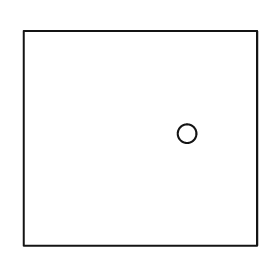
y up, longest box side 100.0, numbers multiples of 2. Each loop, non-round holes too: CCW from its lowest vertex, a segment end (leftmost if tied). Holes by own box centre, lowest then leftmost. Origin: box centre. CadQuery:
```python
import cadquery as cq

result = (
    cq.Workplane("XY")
    .moveTo(-50.0, -46.0)
    .lineTo(50.0, -46.0)
    .lineTo(50.0, 46.0)
    .lineTo(-50.0, 46.0)
    .close()
    .moveTo(20.0, 2.0)
    .circle(4.0)
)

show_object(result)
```